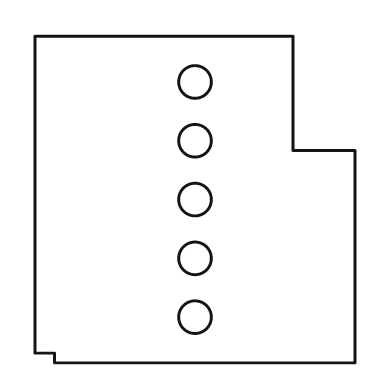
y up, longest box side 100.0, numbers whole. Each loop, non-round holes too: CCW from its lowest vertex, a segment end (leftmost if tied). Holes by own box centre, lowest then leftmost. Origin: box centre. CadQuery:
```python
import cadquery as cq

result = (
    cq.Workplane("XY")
    .moveTo(-43.0, -50.0)
    .lineTo(49.0, -50.0)
    .lineTo(49.0, 15.0)
    .lineTo(30.0, 15.0)
    .lineTo(30.0, 50.0)
    .lineTo(-49.0, 50.0)
    .lineTo(-49.0, -47.0)
    .lineTo(-43.0, -47.0)
    .close()
    .moveTo(0.0, -36.0)
    .circle(5.0)
    .moveTo(0.0, -18.0)
    .circle(5.0)
    .moveTo(0.0, 0.0)
    .circle(5.0)
    .moveTo(0.0, 18.0)
    .circle(5.0)
    .moveTo(0.0, 36.0)
    .circle(5.0)
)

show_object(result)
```